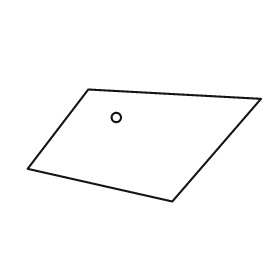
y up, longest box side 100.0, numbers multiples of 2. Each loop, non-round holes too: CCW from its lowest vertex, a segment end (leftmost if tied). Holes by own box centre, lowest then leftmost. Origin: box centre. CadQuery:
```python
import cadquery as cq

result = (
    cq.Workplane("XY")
    .moveTo(12.0, -24.0)
    .lineTo(50.0, 20.0)
    .lineTo(-24.0, 24.0)
    .lineTo(-50.0, -10.0)
    .close()
    .moveTo(-12.0, 12.0)
    .circle(2.0)
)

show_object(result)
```